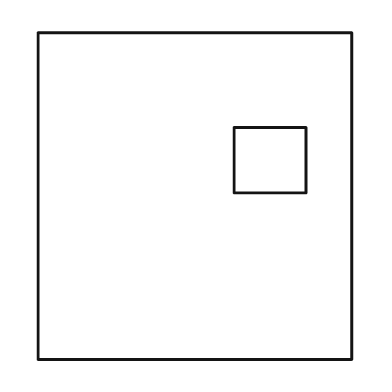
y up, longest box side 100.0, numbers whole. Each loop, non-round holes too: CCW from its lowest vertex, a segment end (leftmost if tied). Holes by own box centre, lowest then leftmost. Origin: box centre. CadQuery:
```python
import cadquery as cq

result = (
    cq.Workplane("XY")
    .moveTo(-48.0, -50.0)
    .lineTo(48.0, -50.0)
    .lineTo(48.0, 50.0)
    .lineTo(-48.0, 50.0)
    .close()
    .moveTo(12.0, 1.0)
    .lineTo(34.0, 1.0)
    .lineTo(34.0, 21.0)
    .lineTo(12.0, 21.0)
    .close()
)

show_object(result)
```